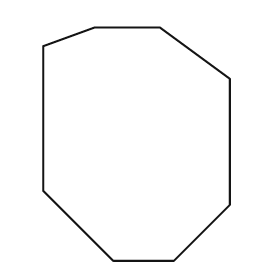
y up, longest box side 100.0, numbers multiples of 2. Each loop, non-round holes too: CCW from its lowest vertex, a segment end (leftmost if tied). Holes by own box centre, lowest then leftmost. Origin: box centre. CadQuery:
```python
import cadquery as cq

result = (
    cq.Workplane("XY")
    .moveTo(-10.0, -50.0)
    .lineTo(16.0, -50.0)
    .lineTo(40.0, -26.0)
    .lineTo(40.0, 28.0)
    .lineTo(10.0, 50.0)
    .lineTo(-18.0, 50.0)
    .lineTo(-40.0, 42.0)
    .lineTo(-40.0, -20.0)
    .close()
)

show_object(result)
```